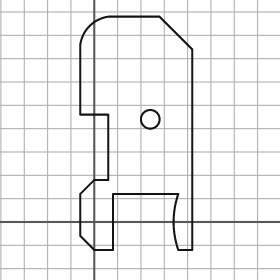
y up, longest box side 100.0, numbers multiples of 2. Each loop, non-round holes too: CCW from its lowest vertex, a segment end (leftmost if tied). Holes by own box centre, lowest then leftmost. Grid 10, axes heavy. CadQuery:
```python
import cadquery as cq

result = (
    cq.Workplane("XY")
    .moveTo(0.0, -12.0)
    .lineTo(8.0, -12.0)
    .lineTo(8.0, 12.0)
    .lineTo(36.0, 12.0)
    .threePointArc((34.0, 0.0), (36.0, -12.0))
    .lineTo(42.0, -12.0)
    .lineTo(42.0, 74.0)
    .lineTo(28.0, 88.0)
    .lineTo(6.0, 88.0)
    .threePointArc((-2.0, 84.0), (-6.0, 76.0))
    .lineTo(-6.0, 46.0)
    .lineTo(6.0, 46.0)
    .lineTo(6.0, 18.0)
    .lineTo(0.0, 18.0)
    .lineTo(-6.0, 12.0)
    .lineTo(-6.0, -6.0)
    .close()
    .moveTo(24.0, 44.0)
    .circle(4.0)
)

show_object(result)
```